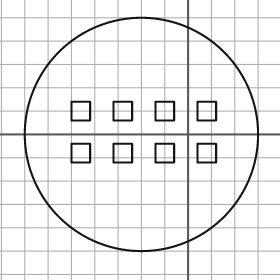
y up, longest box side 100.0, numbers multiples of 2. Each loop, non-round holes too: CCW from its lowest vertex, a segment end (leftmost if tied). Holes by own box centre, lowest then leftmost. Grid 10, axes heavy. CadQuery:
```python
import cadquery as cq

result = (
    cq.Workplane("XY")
    .moveTo(-20.0, 0.0)
    .circle(50.0)
    .moveTo(-50.0, -12.0)
    .lineTo(-42.0, -12.0)
    .lineTo(-42.0, -4.0)
    .lineTo(-50.0, -4.0)
    .close()
    .moveTo(-32.0, -12.0)
    .lineTo(-24.0, -12.0)
    .lineTo(-24.0, -4.0)
    .lineTo(-32.0, -4.0)
    .close()
    .moveTo(-14.0, -12.0)
    .lineTo(-6.0, -12.0)
    .lineTo(-6.0, -4.0)
    .lineTo(-14.0, -4.0)
    .close()
    .moveTo(4.0, -12.0)
    .lineTo(12.0, -12.0)
    .lineTo(12.0, -4.0)
    .lineTo(4.0, -4.0)
    .close()
    .moveTo(-50.0, 6.0)
    .lineTo(-42.0, 6.0)
    .lineTo(-42.0, 14.0)
    .lineTo(-50.0, 14.0)
    .close()
    .moveTo(-32.0, 6.0)
    .lineTo(-24.0, 6.0)
    .lineTo(-24.0, 14.0)
    .lineTo(-32.0, 14.0)
    .close()
    .moveTo(-14.0, 6.0)
    .lineTo(-6.0, 6.0)
    .lineTo(-6.0, 14.0)
    .lineTo(-14.0, 14.0)
    .close()
    .moveTo(4.0, 6.0)
    .lineTo(12.0, 6.0)
    .lineTo(12.0, 14.0)
    .lineTo(4.0, 14.0)
    .close()
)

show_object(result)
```